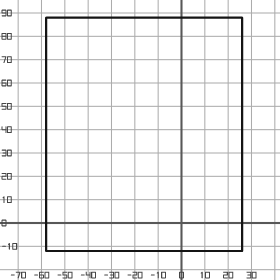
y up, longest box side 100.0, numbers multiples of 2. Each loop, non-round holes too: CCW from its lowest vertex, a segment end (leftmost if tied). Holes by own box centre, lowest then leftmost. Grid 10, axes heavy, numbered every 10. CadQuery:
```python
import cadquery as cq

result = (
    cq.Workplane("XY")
    .moveTo(-58.0, -12.0)
    .lineTo(26.0, -12.0)
    .lineTo(26.0, 88.0)
    .lineTo(-58.0, 88.0)
    .close()
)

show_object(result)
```